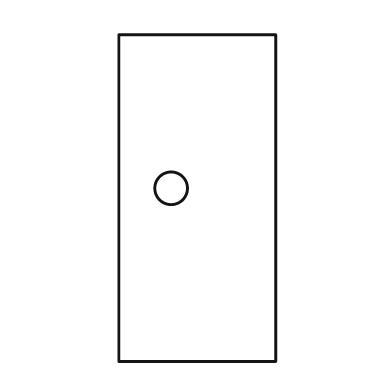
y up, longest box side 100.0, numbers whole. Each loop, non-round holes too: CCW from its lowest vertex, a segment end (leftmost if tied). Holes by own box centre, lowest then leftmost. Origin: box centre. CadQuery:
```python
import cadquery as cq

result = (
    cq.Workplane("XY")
    .moveTo(-24.0, -50.0)
    .lineTo(24.0, -50.0)
    .lineTo(24.0, 50.0)
    .lineTo(-24.0, 50.0)
    .close()
    .moveTo(-8.0, 3.0)
    .circle(5.0)
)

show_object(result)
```